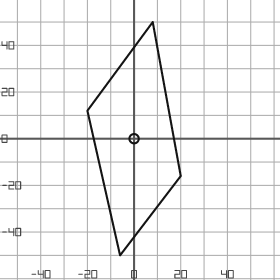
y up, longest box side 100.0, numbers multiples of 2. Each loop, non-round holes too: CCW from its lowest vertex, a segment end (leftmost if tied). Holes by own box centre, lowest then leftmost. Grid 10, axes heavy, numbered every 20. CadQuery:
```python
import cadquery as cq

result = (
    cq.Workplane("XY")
    .moveTo(-6.0, -50.0)
    .lineTo(20.0, -16.0)
    .lineTo(8.0, 50.0)
    .lineTo(-20.0, 12.0)
    .close()
    .moveTo(0.0, 0.0)
    .circle(2.0)
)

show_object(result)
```